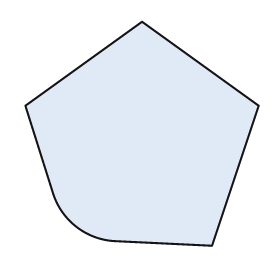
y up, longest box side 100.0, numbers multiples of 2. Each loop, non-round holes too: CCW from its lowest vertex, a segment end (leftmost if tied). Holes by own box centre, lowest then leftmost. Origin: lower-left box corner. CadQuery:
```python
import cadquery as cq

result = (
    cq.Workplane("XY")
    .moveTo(80.0, 0.0)
    .lineTo(100.0, 60.0)
    .lineTo(50.0, 96.0)
    .lineTo(0.0, 60.0)
    .lineTo(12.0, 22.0)
    .threePointArc((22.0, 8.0), (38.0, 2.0))
    .close()
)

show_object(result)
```